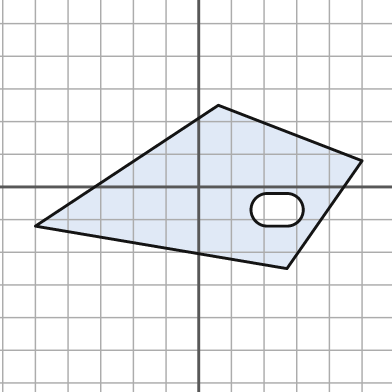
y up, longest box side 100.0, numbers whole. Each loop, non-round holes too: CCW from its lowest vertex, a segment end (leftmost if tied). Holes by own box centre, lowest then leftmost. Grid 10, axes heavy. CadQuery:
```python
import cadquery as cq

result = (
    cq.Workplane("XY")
    .moveTo(27.0, -25.0)
    .lineTo(50.0, 8.0)
    .lineTo(6.0, 25.0)
    .lineTo(-50.0, -12.0)
    .close()
    .moveTo(21.0, -12.0)
    .lineTo(27.0, -12.0)
    .threePointArc((32.0, -7.0), (27.0, -2.0))
    .lineTo(21.0, -2.0)
    .threePointArc((16.0, -7.0), (21.0, -12.0))
    .close()
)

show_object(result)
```